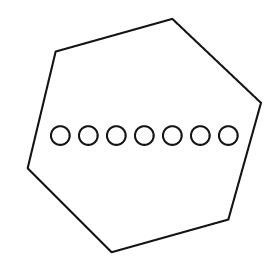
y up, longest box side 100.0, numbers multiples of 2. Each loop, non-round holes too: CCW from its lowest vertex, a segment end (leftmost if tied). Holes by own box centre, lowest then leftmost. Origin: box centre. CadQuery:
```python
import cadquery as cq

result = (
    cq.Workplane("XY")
    .moveTo(-14.0, -50.0)
    .lineTo(36.0, -36.0)
    .lineTo(50.0, 14.0)
    .lineTo(12.0, 50.0)
    .lineTo(-38.0, 36.0)
    .lineTo(-50.0, -14.0)
    .close()
    .moveTo(-36.0, 0.0)
    .circle(4.0)
    .moveTo(-24.0, 0.0)
    .circle(4.0)
    .moveTo(-12.0, 0.0)
    .circle(4.0)
    .moveTo(0.0, 0.0)
    .circle(4.0)
    .moveTo(12.0, 0.0)
    .circle(4.0)
    .moveTo(24.0, 0.0)
    .circle(4.0)
    .moveTo(36.0, 0.0)
    .circle(4.0)
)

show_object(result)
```